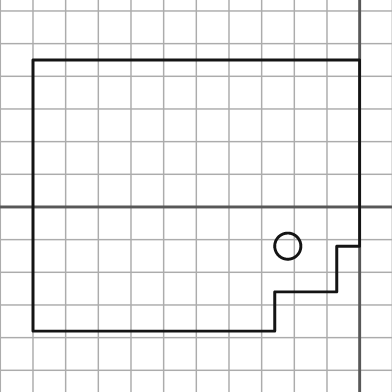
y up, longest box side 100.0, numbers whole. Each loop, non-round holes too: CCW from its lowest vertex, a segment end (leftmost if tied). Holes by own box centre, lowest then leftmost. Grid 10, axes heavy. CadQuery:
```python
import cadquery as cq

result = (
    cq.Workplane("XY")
    .moveTo(-100.0, -38.0)
    .lineTo(-26.0, -38.0)
    .lineTo(-26.0, -26.0)
    .lineTo(-7.0, -26.0)
    .lineTo(-7.0, -12.0)
    .lineTo(0.0, -12.0)
    .lineTo(0.0, 45.0)
    .lineTo(-100.0, 45.0)
    .close()
    .moveTo(-22.0, -12.0)
    .circle(4.0)
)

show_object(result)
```